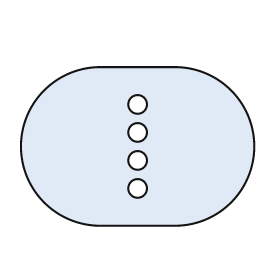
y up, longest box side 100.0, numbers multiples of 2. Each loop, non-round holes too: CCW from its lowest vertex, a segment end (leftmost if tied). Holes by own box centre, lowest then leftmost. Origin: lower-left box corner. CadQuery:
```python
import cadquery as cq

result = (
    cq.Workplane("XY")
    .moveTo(34.0, 0.0)
    .lineTo(66.0, 0.0)
    .threePointArc((100.0, 34.0), (66.0, 68.0))
    .lineTo(34.0, 68.0)
    .threePointArc((0.0, 34.0), (34.0, 0.0))
    .close()
    .moveTo(50.0, 16.0)
    .circle(4.0)
    .moveTo(50.0, 28.0)
    .circle(4.0)
    .moveTo(50.0, 40.0)
    .circle(4.0)
    .moveTo(50.0, 52.0)
    .circle(4.0)
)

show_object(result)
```